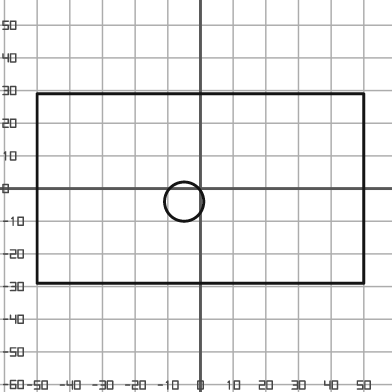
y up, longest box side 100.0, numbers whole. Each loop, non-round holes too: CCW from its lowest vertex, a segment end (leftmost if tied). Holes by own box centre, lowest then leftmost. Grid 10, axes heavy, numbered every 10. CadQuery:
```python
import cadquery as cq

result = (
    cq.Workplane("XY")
    .moveTo(-50.0, -29.0)
    .lineTo(50.0, -29.0)
    .lineTo(50.0, 29.0)
    .lineTo(-50.0, 29.0)
    .close()
    .moveTo(-5.0, -4.0)
    .circle(6.0)
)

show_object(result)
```